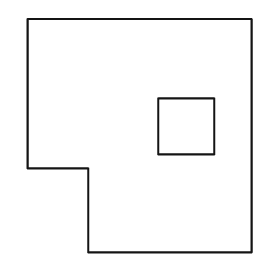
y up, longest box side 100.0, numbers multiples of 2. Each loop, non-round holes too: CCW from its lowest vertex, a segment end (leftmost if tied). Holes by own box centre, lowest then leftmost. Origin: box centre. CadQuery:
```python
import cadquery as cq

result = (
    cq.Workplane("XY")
    .moveTo(-22.0, -50.0)
    .lineTo(48.0, -50.0)
    .lineTo(48.0, 50.0)
    .lineTo(-48.0, 50.0)
    .lineTo(-48.0, -14.0)
    .lineTo(-22.0, -14.0)
    .close()
    .moveTo(8.0, -8.0)
    .lineTo(32.0, -8.0)
    .lineTo(32.0, 16.0)
    .lineTo(8.0, 16.0)
    .close()
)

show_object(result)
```